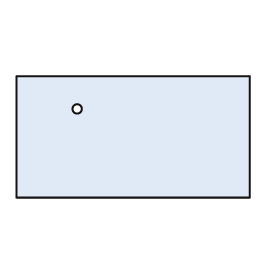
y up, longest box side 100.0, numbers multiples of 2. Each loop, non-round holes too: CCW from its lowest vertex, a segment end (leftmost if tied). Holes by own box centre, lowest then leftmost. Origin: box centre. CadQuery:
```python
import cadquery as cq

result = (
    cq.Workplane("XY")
    .moveTo(-50.0, -26.0)
    .lineTo(50.0, -26.0)
    .lineTo(50.0, 26.0)
    .lineTo(-50.0, 26.0)
    .close()
    .moveTo(-24.0, 12.0)
    .circle(2.0)
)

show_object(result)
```